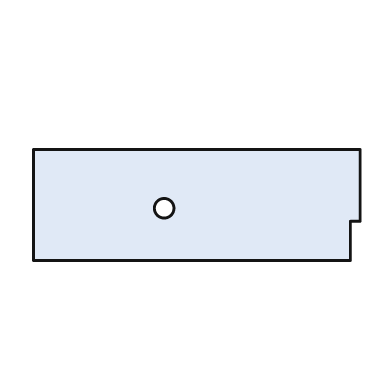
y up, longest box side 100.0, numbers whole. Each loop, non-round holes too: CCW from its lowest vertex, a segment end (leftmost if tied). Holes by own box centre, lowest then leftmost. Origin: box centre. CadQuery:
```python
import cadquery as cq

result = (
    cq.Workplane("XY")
    .moveTo(-50.0, -17.0)
    .lineTo(47.0, -17.0)
    .lineTo(47.0, -5.0)
    .lineTo(50.0, -5.0)
    .lineTo(50.0, 17.0)
    .lineTo(-50.0, 17.0)
    .close()
    .moveTo(-10.0, -1.0)
    .circle(3.0)
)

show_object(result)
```